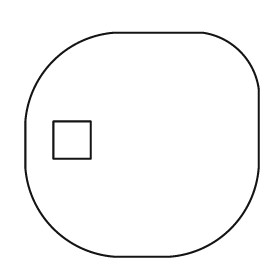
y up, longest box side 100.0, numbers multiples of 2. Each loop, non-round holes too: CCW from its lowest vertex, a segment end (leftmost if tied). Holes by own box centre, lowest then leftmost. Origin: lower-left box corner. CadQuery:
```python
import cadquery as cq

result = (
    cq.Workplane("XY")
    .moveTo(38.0, 0.0)
    .lineTo(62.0, 0.0)
    .threePointArc((88.0, 12.0), (100.0, 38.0))
    .lineTo(100.0, 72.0)
    .threePointArc((92.0, 88.0), (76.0, 96.0))
    .lineTo(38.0, 96.0)
    .threePointArc((12.0, 84.0), (0.0, 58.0))
    .lineTo(0.0, 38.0)
    .threePointArc((12.0, 12.0), (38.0, 0.0))
    .close()
    .moveTo(12.0, 42.0)
    .lineTo(28.0, 42.0)
    .lineTo(28.0, 58.0)
    .lineTo(12.0, 58.0)
    .close()
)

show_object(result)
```